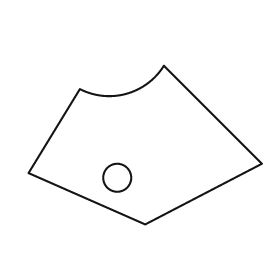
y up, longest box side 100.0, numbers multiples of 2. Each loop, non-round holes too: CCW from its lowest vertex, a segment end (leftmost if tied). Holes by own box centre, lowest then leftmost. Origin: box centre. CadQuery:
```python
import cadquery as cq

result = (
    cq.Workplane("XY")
    .moveTo(0.0, -34.0)
    .lineTo(50.0, -8.0)
    .lineTo(8.0, 34.0)
    .threePointArc((-8.0, 22.0), (-28.0, 24.0))
    .lineTo(-50.0, -12.0)
    .close()
    .moveTo(-12.0, -14.0)
    .circle(6.0)
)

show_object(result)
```